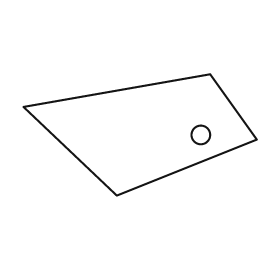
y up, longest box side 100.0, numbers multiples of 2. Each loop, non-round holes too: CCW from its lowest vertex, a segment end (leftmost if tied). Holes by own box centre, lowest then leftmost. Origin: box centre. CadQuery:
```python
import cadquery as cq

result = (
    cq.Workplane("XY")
    .moveTo(-10.0, -26.0)
    .lineTo(50.0, -2.0)
    .lineTo(30.0, 26.0)
    .lineTo(-50.0, 12.0)
    .close()
    .moveTo(26.0, 0.0)
    .circle(4.0)
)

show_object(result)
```